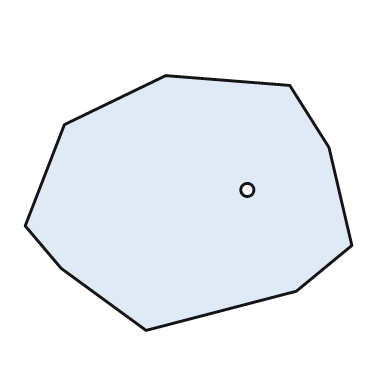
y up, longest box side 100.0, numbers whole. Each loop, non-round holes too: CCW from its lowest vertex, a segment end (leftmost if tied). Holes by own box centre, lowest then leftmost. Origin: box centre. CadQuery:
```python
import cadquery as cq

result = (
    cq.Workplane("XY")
    .moveTo(-13.0, -39.0)
    .lineTo(33.0, -27.0)
    .lineTo(50.0, -13.0)
    .lineTo(43.0, 17.0)
    .lineTo(31.0, 36.0)
    .lineTo(-7.0, 39.0)
    .lineTo(-38.0, 24.0)
    .lineTo(-50.0, -7.0)
    .lineTo(-39.0, -20.0)
    .close()
    .moveTo(18.0, 4.0)
    .circle(2.0)
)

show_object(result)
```